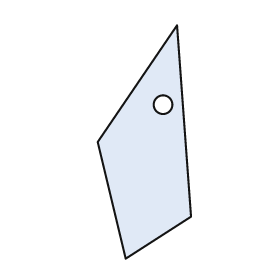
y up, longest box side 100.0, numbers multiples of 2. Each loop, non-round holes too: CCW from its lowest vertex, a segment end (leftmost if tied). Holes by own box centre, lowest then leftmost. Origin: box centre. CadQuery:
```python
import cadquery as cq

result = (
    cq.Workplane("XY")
    .moveTo(-8.0, -50.0)
    .lineTo(20.0, -32.0)
    .lineTo(14.0, 50.0)
    .lineTo(-20.0, 0.0)
    .close()
    .moveTo(8.0, 16.0)
    .circle(4.0)
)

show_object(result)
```